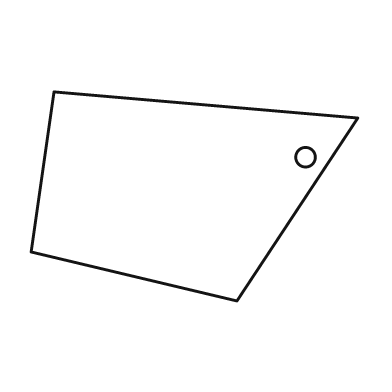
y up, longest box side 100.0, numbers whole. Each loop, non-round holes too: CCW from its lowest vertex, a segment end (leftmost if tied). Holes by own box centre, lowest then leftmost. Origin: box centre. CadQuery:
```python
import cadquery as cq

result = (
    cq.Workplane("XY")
    .moveTo(13.0, -32.0)
    .lineTo(50.0, 24.0)
    .lineTo(-43.0, 32.0)
    .lineTo(-50.0, -17.0)
    .close()
    .moveTo(34.0, 12.0)
    .circle(3.0)
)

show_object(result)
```